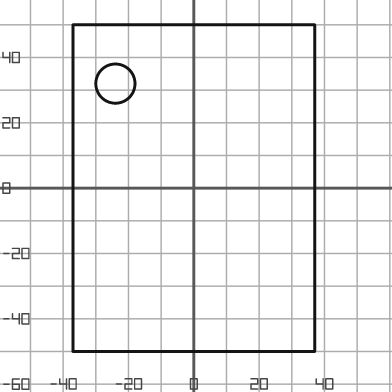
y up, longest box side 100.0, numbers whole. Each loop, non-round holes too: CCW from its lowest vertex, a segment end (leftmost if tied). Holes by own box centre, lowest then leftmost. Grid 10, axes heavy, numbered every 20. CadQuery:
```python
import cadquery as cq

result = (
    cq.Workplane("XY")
    .moveTo(-37.0, -50.0)
    .lineTo(37.0, -50.0)
    .lineTo(37.0, 50.0)
    .lineTo(-37.0, 50.0)
    .close()
    .moveTo(-24.0, 32.0)
    .circle(6.0)
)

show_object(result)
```